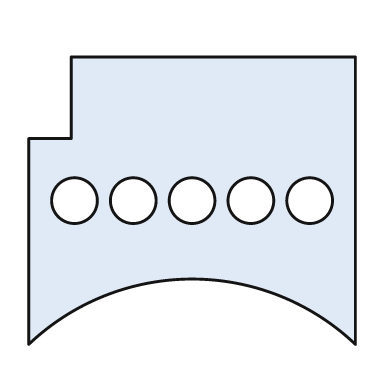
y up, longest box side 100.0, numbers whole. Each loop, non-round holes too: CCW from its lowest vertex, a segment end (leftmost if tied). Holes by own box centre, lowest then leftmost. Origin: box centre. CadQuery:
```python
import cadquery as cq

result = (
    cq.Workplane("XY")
    .moveTo(-50.0, -44.0)
    .threePointArc((0.0, -24.0), (50.0, -44.0))
    .lineTo(50.0, 44.0)
    .lineTo(-37.0, 44.0)
    .lineTo(-37.0, 19.0)
    .lineTo(-50.0, 19.0)
    .close()
    .moveTo(-36.0, 0.0)
    .circle(7.0)
    .moveTo(-18.0, 0.0)
    .circle(7.0)
    .moveTo(0.0, 0.0)
    .circle(7.0)
    .moveTo(18.0, 0.0)
    .circle(7.0)
    .moveTo(36.0, 0.0)
    .circle(7.0)
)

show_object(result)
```